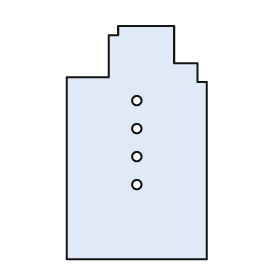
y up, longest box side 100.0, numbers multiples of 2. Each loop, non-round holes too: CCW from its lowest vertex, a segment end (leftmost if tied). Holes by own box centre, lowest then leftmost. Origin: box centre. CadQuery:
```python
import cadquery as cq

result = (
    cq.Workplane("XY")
    .moveTo(-30.0, -50.0)
    .lineTo(30.0, -50.0)
    .lineTo(30.0, 26.0)
    .lineTo(26.0, 26.0)
    .lineTo(26.0, 34.0)
    .lineTo(16.0, 34.0)
    .lineTo(16.0, 50.0)
    .lineTo(-8.0, 50.0)
    .lineTo(-8.0, 46.0)
    .lineTo(-12.0, 46.0)
    .lineTo(-12.0, 28.0)
    .lineTo(-30.0, 28.0)
    .close()
    .moveTo(0.0, -18.0)
    .circle(2.0)
    .moveTo(0.0, -6.0)
    .circle(2.0)
    .moveTo(0.0, 6.0)
    .circle(2.0)
    .moveTo(0.0, 18.0)
    .circle(2.0)
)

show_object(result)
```